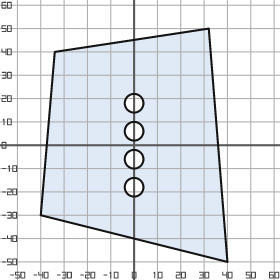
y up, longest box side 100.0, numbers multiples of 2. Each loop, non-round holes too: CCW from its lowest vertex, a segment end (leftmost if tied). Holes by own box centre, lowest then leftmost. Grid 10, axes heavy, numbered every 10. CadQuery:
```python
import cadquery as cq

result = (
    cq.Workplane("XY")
    .moveTo(40.0, -50.0)
    .lineTo(32.0, 50.0)
    .lineTo(-34.0, 40.0)
    .lineTo(-40.0, -30.0)
    .close()
    .moveTo(0.0, -18.0)
    .circle(4.0)
    .moveTo(0.0, -6.0)
    .circle(4.0)
    .moveTo(0.0, 6.0)
    .circle(4.0)
    .moveTo(0.0, 18.0)
    .circle(4.0)
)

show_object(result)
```